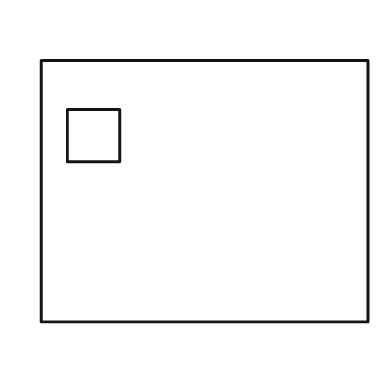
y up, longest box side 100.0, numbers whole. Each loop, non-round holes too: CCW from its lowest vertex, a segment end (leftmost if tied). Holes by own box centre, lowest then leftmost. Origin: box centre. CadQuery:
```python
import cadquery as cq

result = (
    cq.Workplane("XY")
    .moveTo(-50.0, -40.0)
    .lineTo(50.0, -40.0)
    .lineTo(50.0, 40.0)
    .lineTo(-50.0, 40.0)
    .close()
    .moveTo(-42.0, 9.0)
    .lineTo(-26.0, 9.0)
    .lineTo(-26.0, 25.0)
    .lineTo(-42.0, 25.0)
    .close()
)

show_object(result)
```